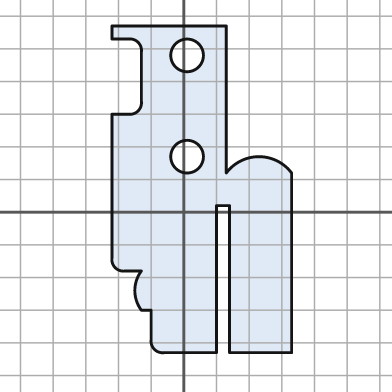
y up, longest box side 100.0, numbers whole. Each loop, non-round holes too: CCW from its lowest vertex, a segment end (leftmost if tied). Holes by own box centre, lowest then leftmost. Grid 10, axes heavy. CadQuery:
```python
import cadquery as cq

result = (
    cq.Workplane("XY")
    .moveTo(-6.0, -43.0)
    .lineTo(10.0, -43.0)
    .lineTo(10.0, 2.0)
    .lineTo(14.0, 2.0)
    .lineTo(14.0, -43.0)
    .lineTo(33.0, -43.0)
    .lineTo(33.0, 12.0)
    .threePointArc((23.0, 17.0), (13.0, 12.0))
    .lineTo(13.0, 57.0)
    .lineTo(-22.0, 57.0)
    .lineTo(-22.0, 53.0)
    .lineTo(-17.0, 53.0)
    .threePointArc((-14.0, 52.0), (-13.0, 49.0))
    .lineTo(-13.0, 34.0)
    .threePointArc((-14.0, 31.0), (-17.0, 30.0))
    .lineTo(-22.0, 30.0)
    .lineTo(-22.0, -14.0)
    .threePointArc((-21.0, -17.0), (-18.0, -18.0))
    .lineTo(-13.0, -18.0)
    .threePointArc((-15.0, -24.0), (-13.0, -30.0))
    .lineTo(-10.0, -30.0)
    .lineTo(-10.0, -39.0)
    .threePointArc((-9.0, -42.0), (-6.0, -43.0))
    .close()
    .moveTo(1.0, 17.0)
    .circle(5.0)
    .moveTo(1.0, 48.0)
    .circle(5.0)
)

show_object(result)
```